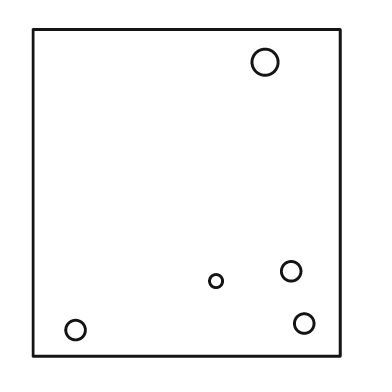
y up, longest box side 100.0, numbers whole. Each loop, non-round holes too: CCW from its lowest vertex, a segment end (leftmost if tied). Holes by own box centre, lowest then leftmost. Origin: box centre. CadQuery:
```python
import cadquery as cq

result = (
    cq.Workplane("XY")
    .moveTo(-47.0, -50.0)
    .lineTo(47.0, -50.0)
    .lineTo(47.0, 50.0)
    .lineTo(-47.0, 50.0)
    .close()
    .moveTo(-34.0, -42.0)
    .circle(3.0)
    .moveTo(36.0, -40.0)
    .circle(3.0)
    .moveTo(9.0, -27.0)
    .circle(2.0)
    .moveTo(32.0, -24.0)
    .circle(3.0)
    .moveTo(24.0, 40.0)
    .circle(4.0)
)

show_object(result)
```